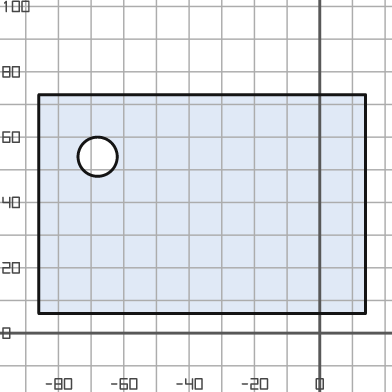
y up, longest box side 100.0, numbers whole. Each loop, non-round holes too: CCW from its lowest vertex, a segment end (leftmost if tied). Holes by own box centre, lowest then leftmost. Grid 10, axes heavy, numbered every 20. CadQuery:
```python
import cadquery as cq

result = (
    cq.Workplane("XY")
    .moveTo(-86.0, 6.0)
    .lineTo(14.0, 6.0)
    .lineTo(14.0, 73.0)
    .lineTo(-86.0, 73.0)
    .close()
    .moveTo(-68.0, 54.0)
    .circle(6.0)
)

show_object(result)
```